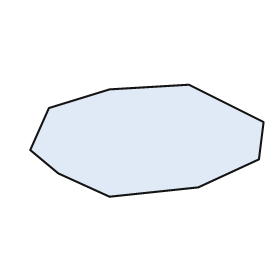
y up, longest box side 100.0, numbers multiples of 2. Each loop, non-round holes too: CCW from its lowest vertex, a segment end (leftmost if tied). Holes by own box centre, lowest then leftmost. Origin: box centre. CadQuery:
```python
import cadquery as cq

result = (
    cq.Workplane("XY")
    .moveTo(-16.0, -24.0)
    .lineTo(22.0, -20.0)
    .lineTo(48.0, -8.0)
    .lineTo(50.0, 8.0)
    .lineTo(18.0, 24.0)
    .lineTo(-16.0, 22.0)
    .lineTo(-42.0, 14.0)
    .lineTo(-50.0, -4.0)
    .lineTo(-38.0, -14.0)
    .close()
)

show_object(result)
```